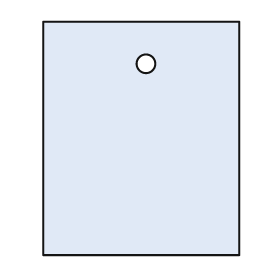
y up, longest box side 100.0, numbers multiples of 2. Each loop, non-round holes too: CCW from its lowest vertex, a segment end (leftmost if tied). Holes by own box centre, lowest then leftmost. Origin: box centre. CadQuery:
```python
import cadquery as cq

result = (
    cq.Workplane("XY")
    .moveTo(-42.0, -50.0)
    .lineTo(42.0, -50.0)
    .lineTo(42.0, 50.0)
    .lineTo(-42.0, 50.0)
    .close()
    .moveTo(2.0, 32.0)
    .circle(4.0)
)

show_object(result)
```